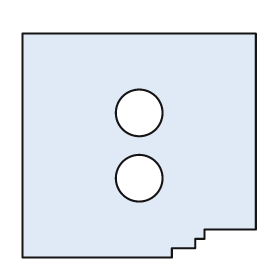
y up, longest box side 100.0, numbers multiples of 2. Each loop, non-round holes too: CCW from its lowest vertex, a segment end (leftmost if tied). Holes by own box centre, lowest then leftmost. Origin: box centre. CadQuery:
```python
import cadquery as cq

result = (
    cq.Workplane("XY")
    .moveTo(-50.0, -48.0)
    .lineTo(14.0, -48.0)
    .lineTo(14.0, -44.0)
    .lineTo(24.0, -44.0)
    .lineTo(24.0, -40.0)
    .lineTo(28.0, -40.0)
    .lineTo(28.0, -36.0)
    .lineTo(50.0, -36.0)
    .lineTo(50.0, 48.0)
    .lineTo(-50.0, 48.0)
    .close()
    .moveTo(0.0, -14.0)
    .circle(10.0)
    .moveTo(0.0, 14.0)
    .circle(10.0)
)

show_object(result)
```